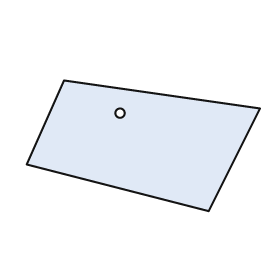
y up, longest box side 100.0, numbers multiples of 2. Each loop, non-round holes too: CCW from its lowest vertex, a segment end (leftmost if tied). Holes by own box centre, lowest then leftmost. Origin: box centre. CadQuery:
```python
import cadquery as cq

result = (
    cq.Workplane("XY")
    .moveTo(28.0, -28.0)
    .lineTo(50.0, 16.0)
    .lineTo(-34.0, 28.0)
    .lineTo(-50.0, -8.0)
    .close()
    .moveTo(-10.0, 14.0)
    .circle(2.0)
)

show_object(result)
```